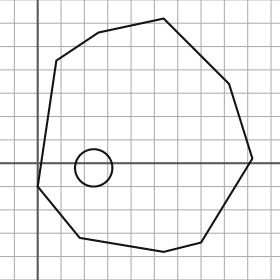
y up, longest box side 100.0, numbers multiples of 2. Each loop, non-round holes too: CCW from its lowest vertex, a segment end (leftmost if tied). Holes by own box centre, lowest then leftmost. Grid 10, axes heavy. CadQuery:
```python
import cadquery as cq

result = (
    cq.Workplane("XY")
    .moveTo(54.0, -38.0)
    .lineTo(70.0, -34.0)
    .lineTo(92.0, 2.0)
    .lineTo(82.0, 34.0)
    .lineTo(54.0, 62.0)
    .lineTo(26.0, 56.0)
    .lineTo(8.0, 44.0)
    .lineTo(0.0, -10.0)
    .lineTo(18.0, -32.0)
    .close()
    .moveTo(24.0, -2.0)
    .circle(8.0)
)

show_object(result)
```